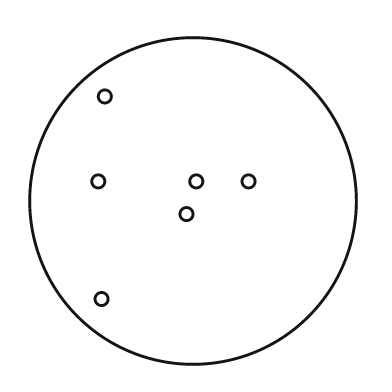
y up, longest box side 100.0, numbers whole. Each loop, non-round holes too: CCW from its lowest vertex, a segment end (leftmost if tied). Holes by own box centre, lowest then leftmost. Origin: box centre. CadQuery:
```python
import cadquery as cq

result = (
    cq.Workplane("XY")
    .moveTo(0.0, 0.0)
    .circle(50.0)
    .moveTo(-28.0, -30.0)
    .circle(2.0)
    .moveTo(-2.0, -4.0)
    .circle(2.0)
    .moveTo(-29.0, 6.0)
    .circle(2.0)
    .moveTo(1.0, 6.0)
    .circle(2.0)
    .moveTo(17.0, 6.0)
    .circle(2.0)
    .moveTo(-27.0, 32.0)
    .circle(2.0)
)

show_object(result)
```